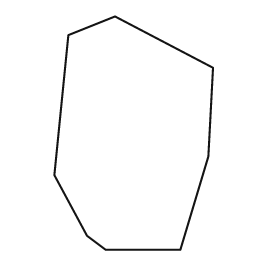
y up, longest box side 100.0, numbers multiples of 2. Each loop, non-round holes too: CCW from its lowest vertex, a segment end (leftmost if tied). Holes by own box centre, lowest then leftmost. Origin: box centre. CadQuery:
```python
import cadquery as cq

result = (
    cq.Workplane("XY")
    .moveTo(-12.0, -50.0)
    .lineTo(20.0, -50.0)
    .lineTo(32.0, -10.0)
    .lineTo(34.0, 28.0)
    .lineTo(-8.0, 50.0)
    .lineTo(-28.0, 42.0)
    .lineTo(-34.0, -18.0)
    .lineTo(-20.0, -44.0)
    .close()
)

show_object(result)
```